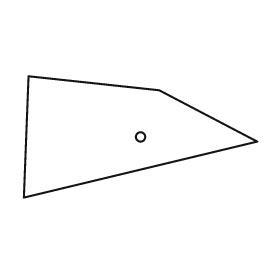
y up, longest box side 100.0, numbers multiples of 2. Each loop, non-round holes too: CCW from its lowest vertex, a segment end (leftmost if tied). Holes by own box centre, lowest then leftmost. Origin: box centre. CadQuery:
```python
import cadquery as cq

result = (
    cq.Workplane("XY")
    .moveTo(-50.0, -26.0)
    .lineTo(50.0, -2.0)
    .lineTo(8.0, 20.0)
    .lineTo(-48.0, 26.0)
    .close()
    .moveTo(0.0, 0.0)
    .circle(2.0)
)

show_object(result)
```